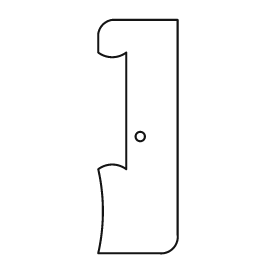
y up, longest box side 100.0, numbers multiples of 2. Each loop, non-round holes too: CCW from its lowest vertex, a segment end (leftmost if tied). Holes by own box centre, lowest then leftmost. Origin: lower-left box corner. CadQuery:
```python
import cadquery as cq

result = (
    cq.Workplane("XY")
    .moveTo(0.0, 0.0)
    .lineTo(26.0, 0.0)
    .threePointArc((32.0, 2.0), (34.0, 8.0))
    .lineTo(34.0, 100.0)
    .lineTo(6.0, 100.0)
    .threePointArc((2.0, 98.0), (0.0, 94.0))
    .lineTo(0.0, 86.0)
    .threePointArc((6.0, 84.0), (12.0, 86.0))
    .lineTo(12.0, 36.0)
    .threePointArc((6.0, 38.0), (0.0, 36.0))
    .threePointArc((2.0, 18.0), (0.0, 0.0))
    .close()
    .moveTo(18.0, 50.0)
    .circle(2.0)
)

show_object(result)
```